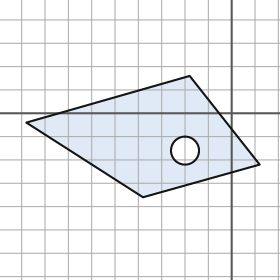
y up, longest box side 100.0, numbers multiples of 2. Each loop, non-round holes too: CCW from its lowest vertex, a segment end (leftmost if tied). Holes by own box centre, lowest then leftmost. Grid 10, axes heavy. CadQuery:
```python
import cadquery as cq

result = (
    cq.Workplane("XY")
    .moveTo(-38.0, -36.0)
    .lineTo(12.0, -22.0)
    .lineTo(-18.0, 16.0)
    .lineTo(-88.0, -4.0)
    .close()
    .moveTo(-20.0, -16.0)
    .circle(6.0)
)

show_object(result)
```